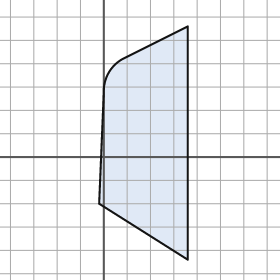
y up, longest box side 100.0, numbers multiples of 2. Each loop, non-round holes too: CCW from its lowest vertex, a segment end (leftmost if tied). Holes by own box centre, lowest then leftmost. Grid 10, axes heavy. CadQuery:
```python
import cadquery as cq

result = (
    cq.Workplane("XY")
    .moveTo(36.0, -44.0)
    .lineTo(36.0, 56.0)
    .lineTo(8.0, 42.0)
    .threePointArc((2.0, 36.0), (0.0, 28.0))
    .lineTo(-2.0, -20.0)
    .close()
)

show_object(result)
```